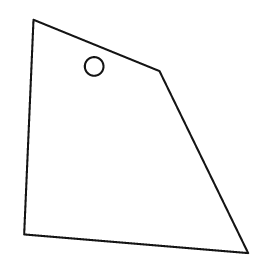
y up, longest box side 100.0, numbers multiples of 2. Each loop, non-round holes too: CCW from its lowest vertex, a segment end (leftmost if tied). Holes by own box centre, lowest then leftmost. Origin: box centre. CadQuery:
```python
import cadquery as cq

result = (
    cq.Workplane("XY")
    .moveTo(48.0, -50.0)
    .lineTo(10.0, 28.0)
    .lineTo(-44.0, 50.0)
    .lineTo(-48.0, -42.0)
    .close()
    .moveTo(-18.0, 30.0)
    .circle(4.0)
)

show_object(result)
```